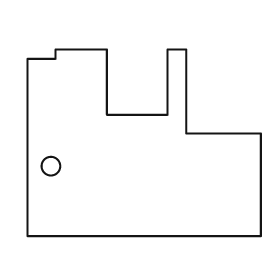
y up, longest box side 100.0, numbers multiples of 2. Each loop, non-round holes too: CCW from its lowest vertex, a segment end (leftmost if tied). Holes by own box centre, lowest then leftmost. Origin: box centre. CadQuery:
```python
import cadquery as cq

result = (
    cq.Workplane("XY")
    .moveTo(-50.0, -40.0)
    .lineTo(50.0, -40.0)
    .lineTo(50.0, 4.0)
    .lineTo(18.0, 4.0)
    .lineTo(18.0, 40.0)
    .lineTo(10.0, 40.0)
    .lineTo(10.0, 12.0)
    .lineTo(-16.0, 12.0)
    .lineTo(-16.0, 40.0)
    .lineTo(-38.0, 40.0)
    .lineTo(-38.0, 36.0)
    .lineTo(-50.0, 36.0)
    .close()
    .moveTo(-40.0, -10.0)
    .circle(4.0)
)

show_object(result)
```